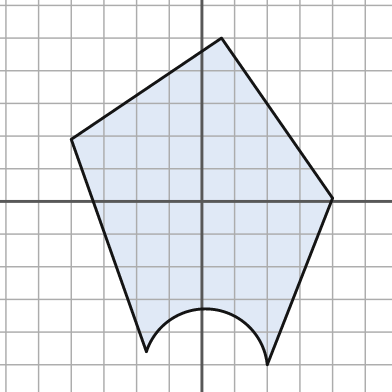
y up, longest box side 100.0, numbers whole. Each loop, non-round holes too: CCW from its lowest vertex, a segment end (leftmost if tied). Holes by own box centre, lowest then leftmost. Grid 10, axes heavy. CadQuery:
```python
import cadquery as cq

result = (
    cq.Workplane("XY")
    .moveTo(20.0, -50.0)
    .lineTo(40.0, 1.0)
    .lineTo(6.0, 50.0)
    .lineTo(-40.0, 19.0)
    .lineTo(-17.0, -46.0)
    .threePointArc((3.0, -33.0), (20.0, -50.0))
    .close()
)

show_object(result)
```